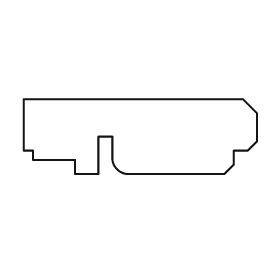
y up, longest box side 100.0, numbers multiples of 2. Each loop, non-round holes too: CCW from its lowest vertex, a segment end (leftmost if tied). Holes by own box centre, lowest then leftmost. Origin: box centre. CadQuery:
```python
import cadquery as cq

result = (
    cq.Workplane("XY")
    .moveTo(-28.0, -16.0)
    .lineTo(-18.0, -16.0)
    .lineTo(-18.0, 0.0)
    .lineTo(-12.0, 0.0)
    .lineTo(-12.0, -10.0)
    .threePointArc((-10.0, -14.0), (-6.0, -16.0))
    .lineTo(36.0, -16.0)
    .lineTo(40.0, -12.0)
    .lineTo(40.0, -6.0)
    .lineTo(46.0, -6.0)
    .lineTo(50.0, -2.0)
    .lineTo(50.0, 10.0)
    .lineTo(44.0, 16.0)
    .lineTo(-50.0, 16.0)
    .lineTo(-50.0, -6.0)
    .lineTo(-46.0, -6.0)
    .lineTo(-46.0, -10.0)
    .lineTo(-28.0, -10.0)
    .close()
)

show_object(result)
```